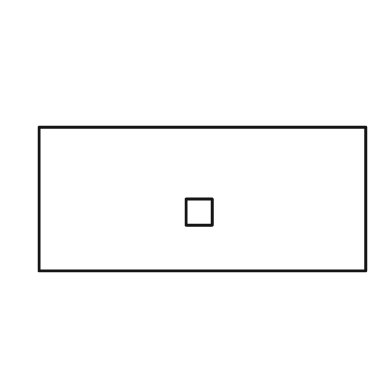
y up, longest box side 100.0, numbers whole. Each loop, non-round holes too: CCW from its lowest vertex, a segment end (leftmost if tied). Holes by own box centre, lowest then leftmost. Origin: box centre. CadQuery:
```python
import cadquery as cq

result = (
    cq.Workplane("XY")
    .moveTo(-50.0, -22.0)
    .lineTo(50.0, -22.0)
    .lineTo(50.0, 22.0)
    .lineTo(-50.0, 22.0)
    .close()
    .moveTo(-5.0, -8.0)
    .lineTo(3.0, -8.0)
    .lineTo(3.0, 0.0)
    .lineTo(-5.0, 0.0)
    .close()
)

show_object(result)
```